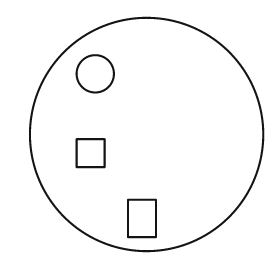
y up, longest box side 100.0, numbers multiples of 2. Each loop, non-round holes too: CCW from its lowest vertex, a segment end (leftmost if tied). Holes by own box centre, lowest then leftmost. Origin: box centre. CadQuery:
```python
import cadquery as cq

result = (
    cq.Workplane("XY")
    .moveTo(0.0, 0.0)
    .circle(50.0)
    .moveTo(-8.0, -44.0)
    .lineTo(4.0, -44.0)
    .lineTo(4.0, -28.0)
    .lineTo(-8.0, -28.0)
    .close()
    .moveTo(-30.0, -14.0)
    .lineTo(-18.0, -14.0)
    .lineTo(-18.0, -2.0)
    .lineTo(-30.0, -2.0)
    .close()
    .moveTo(-22.0, 26.0)
    .circle(8.0)
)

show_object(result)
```